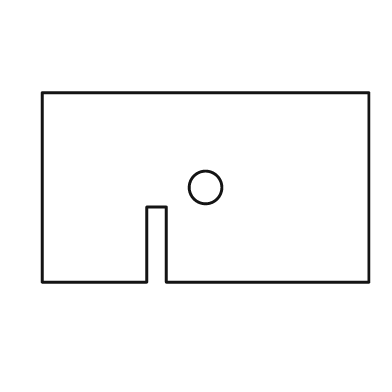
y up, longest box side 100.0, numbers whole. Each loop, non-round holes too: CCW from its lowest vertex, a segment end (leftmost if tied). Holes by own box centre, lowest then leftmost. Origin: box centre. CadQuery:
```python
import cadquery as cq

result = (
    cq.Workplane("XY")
    .moveTo(-50.0, -29.0)
    .lineTo(-18.0, -29.0)
    .lineTo(-18.0, -6.0)
    .lineTo(-12.0, -6.0)
    .lineTo(-12.0, -29.0)
    .lineTo(50.0, -29.0)
    .lineTo(50.0, 29.0)
    .lineTo(-50.0, 29.0)
    .close()
    .moveTo(0.0, 0.0)
    .circle(5.0)
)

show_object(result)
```